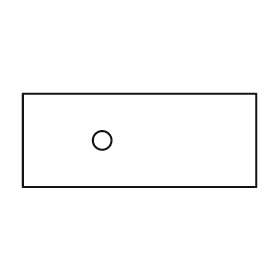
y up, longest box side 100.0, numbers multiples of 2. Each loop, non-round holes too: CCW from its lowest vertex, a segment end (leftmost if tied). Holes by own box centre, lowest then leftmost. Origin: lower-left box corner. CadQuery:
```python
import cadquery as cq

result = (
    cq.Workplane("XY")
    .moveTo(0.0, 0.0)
    .lineTo(100.0, 0.0)
    .lineTo(100.0, 40.0)
    .lineTo(0.0, 40.0)
    .close()
    .moveTo(34.0, 20.0)
    .circle(4.0)
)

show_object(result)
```